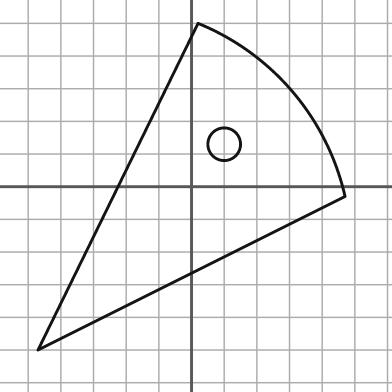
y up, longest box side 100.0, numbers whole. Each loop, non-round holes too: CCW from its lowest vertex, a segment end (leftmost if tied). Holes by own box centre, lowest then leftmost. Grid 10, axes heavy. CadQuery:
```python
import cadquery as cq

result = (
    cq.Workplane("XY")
    .moveTo(-47.0, -50.0)
    .lineTo(47.0, -3.0)
    .threePointArc((31.0, 29.0), (2.0, 50.0))
    .close()
    .moveTo(10.0, 13.0)
    .circle(5.0)
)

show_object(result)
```